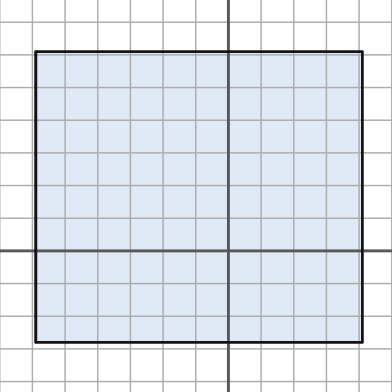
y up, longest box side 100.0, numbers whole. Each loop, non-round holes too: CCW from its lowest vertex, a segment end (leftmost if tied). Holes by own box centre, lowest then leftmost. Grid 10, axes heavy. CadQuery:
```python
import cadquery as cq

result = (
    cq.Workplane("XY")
    .moveTo(-59.0, -28.0)
    .lineTo(41.0, -28.0)
    .lineTo(41.0, 61.0)
    .lineTo(-59.0, 61.0)
    .close()
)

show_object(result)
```